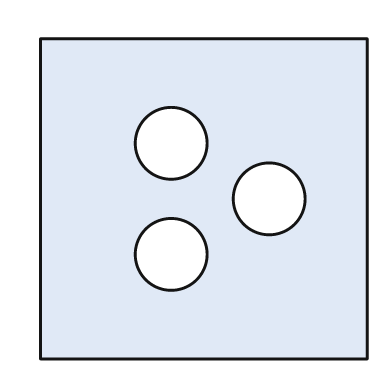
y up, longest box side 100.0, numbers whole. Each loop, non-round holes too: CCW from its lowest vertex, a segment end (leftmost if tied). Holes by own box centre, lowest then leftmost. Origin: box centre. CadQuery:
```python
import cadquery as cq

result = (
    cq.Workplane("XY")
    .moveTo(-50.0, -49.0)
    .lineTo(50.0, -49.0)
    .lineTo(50.0, 49.0)
    .lineTo(-50.0, 49.0)
    .close()
    .moveTo(-10.0, -17.0)
    .circle(11.0)
    .moveTo(20.0, 0.0)
    .circle(11.0)
    .moveTo(-10.0, 17.0)
    .circle(11.0)
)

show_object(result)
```